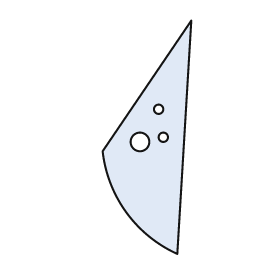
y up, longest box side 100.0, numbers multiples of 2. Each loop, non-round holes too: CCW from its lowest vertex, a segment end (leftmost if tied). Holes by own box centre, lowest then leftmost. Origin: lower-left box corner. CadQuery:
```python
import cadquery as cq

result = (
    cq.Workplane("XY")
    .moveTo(32.0, 0.0)
    .lineTo(38.0, 100.0)
    .lineTo(0.0, 44.0)
    .threePointArc((10.0, 18.0), (32.0, 0.0))
    .close()
    .moveTo(16.0, 48.0)
    .circle(4.0)
    .moveTo(26.0, 50.0)
    .circle(2.0)
    .moveTo(24.0, 62.0)
    .circle(2.0)
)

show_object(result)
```